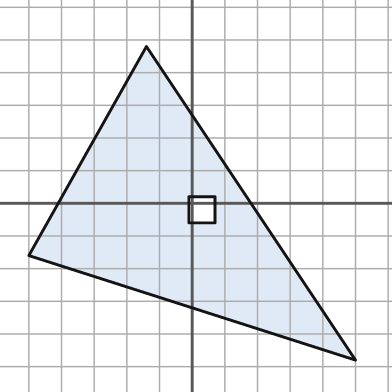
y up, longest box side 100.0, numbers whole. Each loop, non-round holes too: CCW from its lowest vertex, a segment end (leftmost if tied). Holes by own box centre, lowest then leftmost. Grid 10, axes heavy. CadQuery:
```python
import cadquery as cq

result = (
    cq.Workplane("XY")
    .moveTo(50.0, -48.0)
    .lineTo(-14.0, 48.0)
    .lineTo(-50.0, -16.0)
    .close()
    .moveTo(-1.0, -6.0)
    .lineTo(7.0, -6.0)
    .lineTo(7.0, 2.0)
    .lineTo(-1.0, 2.0)
    .close()
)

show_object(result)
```